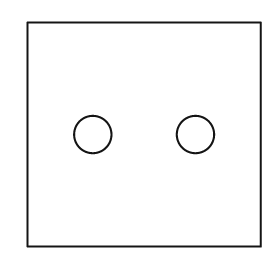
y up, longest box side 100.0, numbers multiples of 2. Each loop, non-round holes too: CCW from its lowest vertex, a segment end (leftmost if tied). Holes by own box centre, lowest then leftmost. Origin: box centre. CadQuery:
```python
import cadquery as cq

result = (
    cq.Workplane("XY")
    .moveTo(-50.0, -48.0)
    .lineTo(50.0, -48.0)
    .lineTo(50.0, 48.0)
    .lineTo(-50.0, 48.0)
    .close()
    .moveTo(-22.0, 0.0)
    .circle(8.0)
    .moveTo(22.0, 0.0)
    .circle(8.0)
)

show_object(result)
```